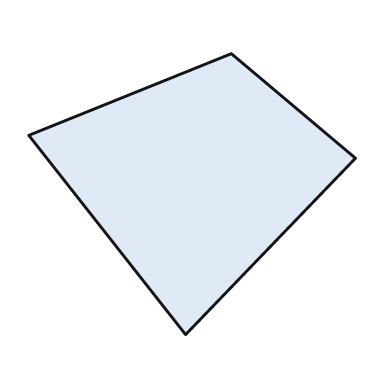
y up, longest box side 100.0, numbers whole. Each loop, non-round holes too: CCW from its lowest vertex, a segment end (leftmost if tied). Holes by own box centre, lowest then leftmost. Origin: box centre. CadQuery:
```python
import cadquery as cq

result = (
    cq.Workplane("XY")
    .moveTo(-2.0, -43.0)
    .lineTo(50.0, 11.0)
    .lineTo(12.0, 43.0)
    .lineTo(-50.0, 18.0)
    .close()
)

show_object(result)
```